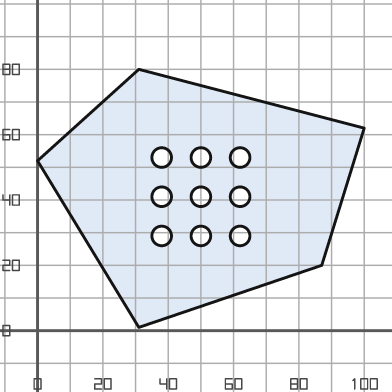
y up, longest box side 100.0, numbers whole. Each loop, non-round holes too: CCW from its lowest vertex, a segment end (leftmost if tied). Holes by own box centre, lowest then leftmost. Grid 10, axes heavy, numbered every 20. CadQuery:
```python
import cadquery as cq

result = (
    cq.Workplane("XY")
    .moveTo(31.0, 1.0)
    .lineTo(87.0, 20.0)
    .lineTo(100.0, 62.0)
    .lineTo(31.0, 80.0)
    .lineTo(0.0, 52.0)
    .close()
    .moveTo(38.0, 29.0)
    .circle(3.0)
    .moveTo(50.0, 29.0)
    .circle(3.0)
    .moveTo(62.0, 29.0)
    .circle(3.0)
    .moveTo(38.0, 41.0)
    .circle(3.0)
    .moveTo(50.0, 41.0)
    .circle(3.0)
    .moveTo(62.0, 41.0)
    .circle(3.0)
    .moveTo(38.0, 53.0)
    .circle(3.0)
    .moveTo(50.0, 53.0)
    .circle(3.0)
    .moveTo(62.0, 53.0)
    .circle(3.0)
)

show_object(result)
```